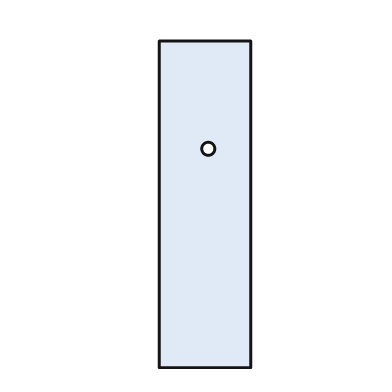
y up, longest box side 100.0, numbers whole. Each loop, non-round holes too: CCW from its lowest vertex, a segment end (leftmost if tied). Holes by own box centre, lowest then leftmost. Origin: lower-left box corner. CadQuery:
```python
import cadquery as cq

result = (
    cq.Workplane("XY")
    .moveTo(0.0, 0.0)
    .lineTo(28.0, 0.0)
    .lineTo(28.0, 100.0)
    .lineTo(0.0, 100.0)
    .close()
    .moveTo(15.0, 67.0)
    .circle(2.0)
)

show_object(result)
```